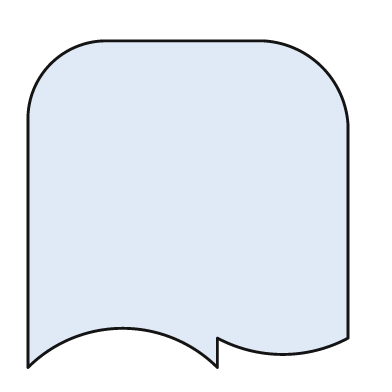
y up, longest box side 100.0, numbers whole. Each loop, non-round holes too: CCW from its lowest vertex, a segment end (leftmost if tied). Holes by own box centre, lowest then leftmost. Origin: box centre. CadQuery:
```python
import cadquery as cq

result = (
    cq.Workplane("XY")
    .moveTo(-49.0, -50.0)
    .threePointArc((-20.0, -38.0), (9.0, -50.0))
    .lineTo(9.0, -41.0)
    .threePointArc((29.0, -46.0), (49.0, -41.0))
    .lineTo(49.0, 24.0)
    .threePointArc((41.0, 42.0), (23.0, 50.0))
    .lineTo(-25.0, 50.0)
    .threePointArc((-42.0, 43.0), (-49.0, 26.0))
    .close()
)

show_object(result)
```